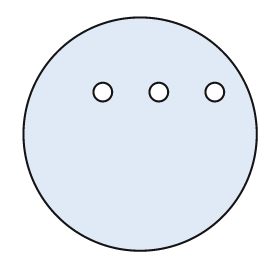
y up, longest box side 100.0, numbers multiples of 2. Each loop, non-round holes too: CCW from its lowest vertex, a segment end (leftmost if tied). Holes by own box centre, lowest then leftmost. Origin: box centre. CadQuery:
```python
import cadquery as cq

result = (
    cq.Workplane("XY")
    .moveTo(0.0, 0.0)
    .circle(50.0)
    .moveTo(-16.0, 18.0)
    .circle(4.0)
    .moveTo(8.0, 18.0)
    .circle(4.0)
    .moveTo(32.0, 18.0)
    .circle(4.0)
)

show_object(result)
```